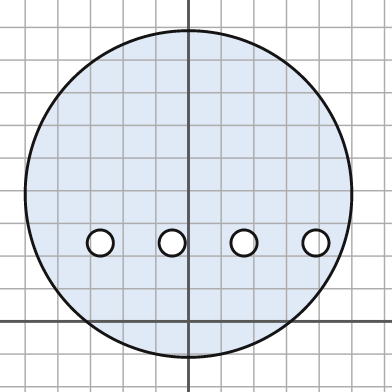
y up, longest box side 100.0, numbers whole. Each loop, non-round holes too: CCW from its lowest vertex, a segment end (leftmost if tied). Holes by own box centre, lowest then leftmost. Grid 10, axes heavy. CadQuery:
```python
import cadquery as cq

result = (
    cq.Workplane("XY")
    .moveTo(0.0, 39.0)
    .circle(50.0)
    .moveTo(-27.0, 24.0)
    .circle(4.0)
    .moveTo(-5.0, 24.0)
    .circle(4.0)
    .moveTo(17.0, 24.0)
    .circle(4.0)
    .moveTo(39.0, 24.0)
    .circle(4.0)
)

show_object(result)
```